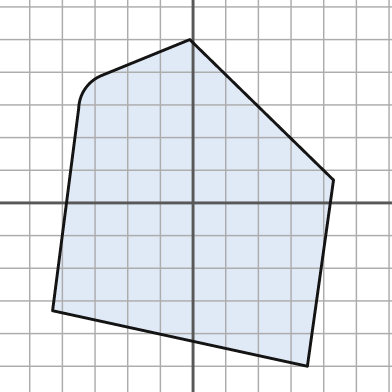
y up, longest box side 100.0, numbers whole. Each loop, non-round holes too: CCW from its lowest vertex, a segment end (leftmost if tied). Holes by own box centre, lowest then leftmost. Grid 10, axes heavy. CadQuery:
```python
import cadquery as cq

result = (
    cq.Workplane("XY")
    .moveTo(35.0, -50.0)
    .lineTo(43.0, 7.0)
    .lineTo(-1.0, 50.0)
    .lineTo(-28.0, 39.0)
    .threePointArc((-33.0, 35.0), (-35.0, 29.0))
    .lineTo(-43.0, -33.0)
    .close()
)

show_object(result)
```